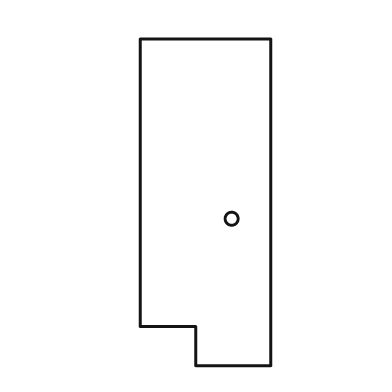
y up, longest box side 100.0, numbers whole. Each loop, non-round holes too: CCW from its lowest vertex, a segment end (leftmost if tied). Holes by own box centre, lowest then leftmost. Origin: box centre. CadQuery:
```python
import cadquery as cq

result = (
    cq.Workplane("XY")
    .moveTo(-3.0, -50.0)
    .lineTo(20.0, -50.0)
    .lineTo(20.0, 50.0)
    .lineTo(-20.0, 50.0)
    .lineTo(-20.0, -38.0)
    .lineTo(-3.0, -38.0)
    .close()
    .moveTo(8.0, -5.0)
    .circle(2.0)
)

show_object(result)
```